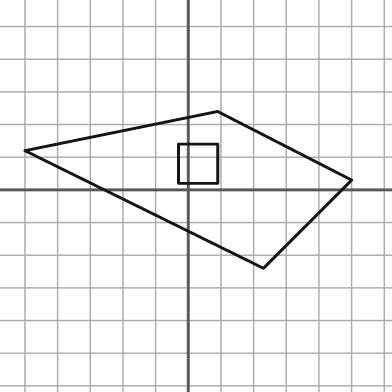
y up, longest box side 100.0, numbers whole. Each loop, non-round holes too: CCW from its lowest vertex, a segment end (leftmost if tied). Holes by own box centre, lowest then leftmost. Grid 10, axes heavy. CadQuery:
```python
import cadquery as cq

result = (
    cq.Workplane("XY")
    .moveTo(23.0, -24.0)
    .lineTo(50.0, 3.0)
    .lineTo(9.0, 24.0)
    .lineTo(-50.0, 12.0)
    .close()
    .moveTo(-3.0, 2.0)
    .lineTo(9.0, 2.0)
    .lineTo(9.0, 14.0)
    .lineTo(-3.0, 14.0)
    .close()
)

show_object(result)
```